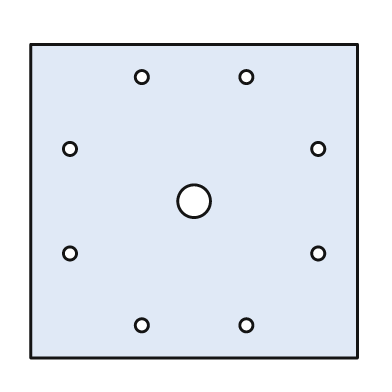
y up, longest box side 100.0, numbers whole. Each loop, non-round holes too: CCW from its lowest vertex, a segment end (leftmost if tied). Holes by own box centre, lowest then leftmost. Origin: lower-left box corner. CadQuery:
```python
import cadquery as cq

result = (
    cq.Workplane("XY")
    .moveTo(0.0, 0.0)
    .lineTo(100.0, 0.0)
    .lineTo(100.0, 96.0)
    .lineTo(0.0, 96.0)
    .close()
    .moveTo(34.0, 10.0)
    .circle(2.0)
    .moveTo(66.0, 10.0)
    .circle(2.0)
    .moveTo(12.0, 32.0)
    .circle(2.0)
    .moveTo(88.0, 32.0)
    .circle(2.0)
    .moveTo(50.0, 48.0)
    .circle(5.0)
    .moveTo(12.0, 64.0)
    .circle(2.0)
    .moveTo(88.0, 64.0)
    .circle(2.0)
    .moveTo(34.0, 86.0)
    .circle(2.0)
    .moveTo(66.0, 86.0)
    .circle(2.0)
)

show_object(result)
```